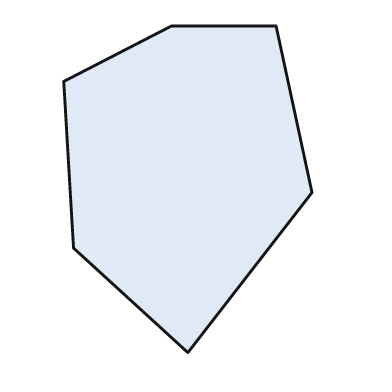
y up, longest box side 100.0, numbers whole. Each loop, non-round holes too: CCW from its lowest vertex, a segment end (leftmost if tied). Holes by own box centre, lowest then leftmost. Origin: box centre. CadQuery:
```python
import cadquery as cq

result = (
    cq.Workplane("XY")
    .moveTo(0.0, -50.0)
    .lineTo(38.0, -1.0)
    .lineTo(27.0, 50.0)
    .lineTo(-5.0, 50.0)
    .lineTo(-38.0, 33.0)
    .lineTo(-35.0, -18.0)
    .close()
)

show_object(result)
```